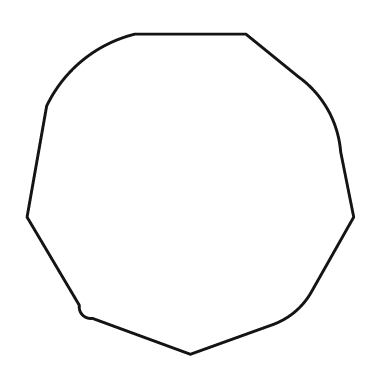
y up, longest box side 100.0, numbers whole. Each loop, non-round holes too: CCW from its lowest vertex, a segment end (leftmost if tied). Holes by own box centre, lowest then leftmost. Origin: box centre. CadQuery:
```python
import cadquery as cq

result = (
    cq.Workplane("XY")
    .moveTo(0.0, -49.0)
    .lineTo(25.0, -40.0)
    .threePointArc((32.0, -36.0), (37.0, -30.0))
    .lineTo(50.0, -7.0)
    .lineTo(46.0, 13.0)
    .threePointArc((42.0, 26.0), (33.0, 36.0))
    .lineTo(17.0, 49.0)
    .lineTo(-17.0, 49.0)
    .threePointArc((-33.0, 41.0), (-44.0, 27.0))
    .lineTo(-50.0, -7.0)
    .lineTo(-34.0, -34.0)
    .threePointArc((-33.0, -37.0), (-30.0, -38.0))
    .close()
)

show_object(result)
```